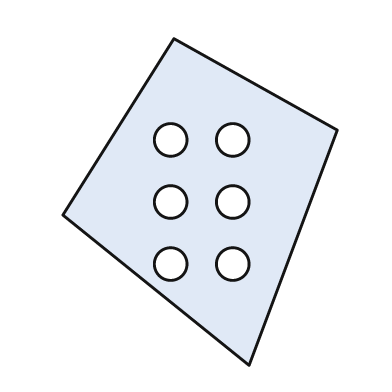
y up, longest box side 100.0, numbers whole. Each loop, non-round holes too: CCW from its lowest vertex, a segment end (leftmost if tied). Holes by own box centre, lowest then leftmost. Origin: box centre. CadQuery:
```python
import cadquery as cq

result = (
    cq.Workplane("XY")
    .moveTo(15.0, -50.0)
    .lineTo(42.0, 22.0)
    .lineTo(-8.0, 50.0)
    .lineTo(-42.0, -4.0)
    .close()
    .moveTo(-9.0, -19.0)
    .circle(5.0)
    .moveTo(10.0, -19.0)
    .circle(5.0)
    .moveTo(-9.0, 0.0)
    .circle(5.0)
    .moveTo(10.0, 0.0)
    .circle(5.0)
    .moveTo(-9.0, 19.0)
    .circle(5.0)
    .moveTo(10.0, 19.0)
    .circle(5.0)
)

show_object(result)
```